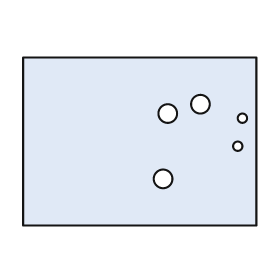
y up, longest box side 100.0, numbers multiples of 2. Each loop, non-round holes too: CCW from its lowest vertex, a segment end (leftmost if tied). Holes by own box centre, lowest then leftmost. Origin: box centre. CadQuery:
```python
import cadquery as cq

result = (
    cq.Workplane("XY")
    .moveTo(-50.0, -36.0)
    .lineTo(50.0, -36.0)
    .lineTo(50.0, 36.0)
    .lineTo(-50.0, 36.0)
    .close()
    .moveTo(10.0, -16.0)
    .circle(4.0)
    .moveTo(42.0, -2.0)
    .circle(2.0)
    .moveTo(44.0, 10.0)
    .circle(2.0)
    .moveTo(12.0, 12.0)
    .circle(4.0)
    .moveTo(26.0, 16.0)
    .circle(4.0)
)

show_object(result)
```